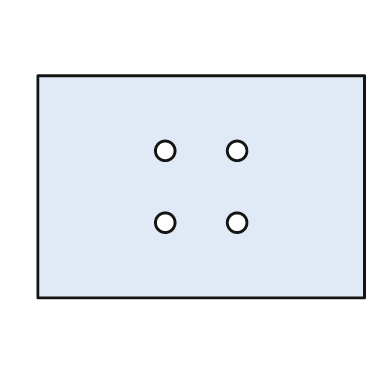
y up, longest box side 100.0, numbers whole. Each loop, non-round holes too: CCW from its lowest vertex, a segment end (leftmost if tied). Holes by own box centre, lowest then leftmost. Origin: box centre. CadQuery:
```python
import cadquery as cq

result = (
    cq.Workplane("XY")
    .moveTo(-50.0, -34.0)
    .lineTo(50.0, -34.0)
    .lineTo(50.0, 34.0)
    .lineTo(-50.0, 34.0)
    .close()
    .moveTo(-11.0, -11.0)
    .circle(3.0)
    .moveTo(11.0, -11.0)
    .circle(3.0)
    .moveTo(-11.0, 11.0)
    .circle(3.0)
    .moveTo(11.0, 11.0)
    .circle(3.0)
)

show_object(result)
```